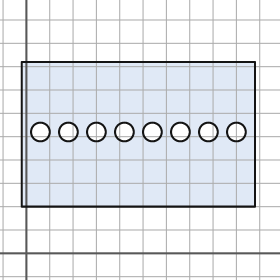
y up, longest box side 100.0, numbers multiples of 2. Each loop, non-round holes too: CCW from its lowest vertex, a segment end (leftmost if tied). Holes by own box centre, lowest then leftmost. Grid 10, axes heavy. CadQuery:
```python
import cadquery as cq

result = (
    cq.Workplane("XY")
    .moveTo(-2.0, 20.0)
    .lineTo(98.0, 20.0)
    .lineTo(98.0, 82.0)
    .lineTo(-2.0, 82.0)
    .close()
    .moveTo(6.0, 52.0)
    .circle(4.0)
    .moveTo(18.0, 52.0)
    .circle(4.0)
    .moveTo(30.0, 52.0)
    .circle(4.0)
    .moveTo(42.0, 52.0)
    .circle(4.0)
    .moveTo(54.0, 52.0)
    .circle(4.0)
    .moveTo(66.0, 52.0)
    .circle(4.0)
    .moveTo(78.0, 52.0)
    .circle(4.0)
    .moveTo(90.0, 52.0)
    .circle(4.0)
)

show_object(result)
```